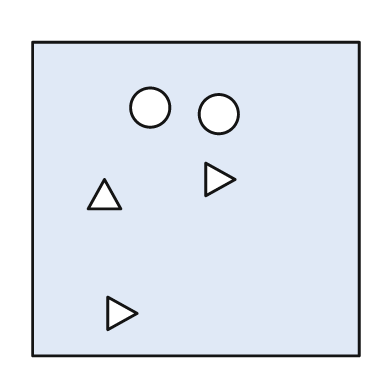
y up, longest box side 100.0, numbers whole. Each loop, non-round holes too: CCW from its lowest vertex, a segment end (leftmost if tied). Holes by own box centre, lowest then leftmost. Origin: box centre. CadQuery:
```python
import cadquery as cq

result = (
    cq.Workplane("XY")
    .moveTo(-50.0, -48.0)
    .lineTo(50.0, -48.0)
    .lineTo(50.0, 48.0)
    .lineTo(-50.0, 48.0)
    .close()
    .moveTo(-27.0, -40.0)
    .lineTo(-18.0, -35.0)
    .lineTo(-27.0, -30.0)
    .close()
    .moveTo(-33.0, -3.0)
    .lineTo(-23.0, -3.0)
    .lineTo(-28.0, 6.0)
    .close()
    .moveTo(3.0, 1.0)
    .lineTo(12.0, 6.0)
    .lineTo(3.0, 11.0)
    .close()
    .moveTo(7.0, 26.0)
    .circle(6.0)
    .moveTo(-14.0, 28.0)
    .circle(6.0)
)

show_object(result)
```